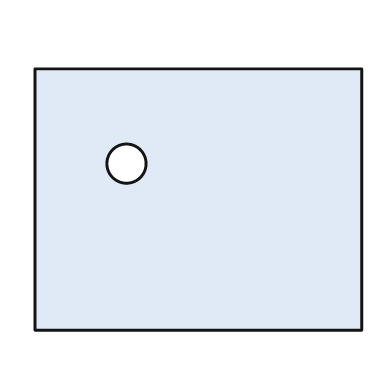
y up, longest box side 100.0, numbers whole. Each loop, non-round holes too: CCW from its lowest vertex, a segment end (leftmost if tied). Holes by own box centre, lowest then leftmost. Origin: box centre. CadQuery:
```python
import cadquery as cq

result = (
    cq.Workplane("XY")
    .moveTo(-50.0, -40.0)
    .lineTo(50.0, -40.0)
    .lineTo(50.0, 40.0)
    .lineTo(-50.0, 40.0)
    .close()
    .moveTo(-22.0, 11.0)
    .circle(6.0)
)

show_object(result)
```